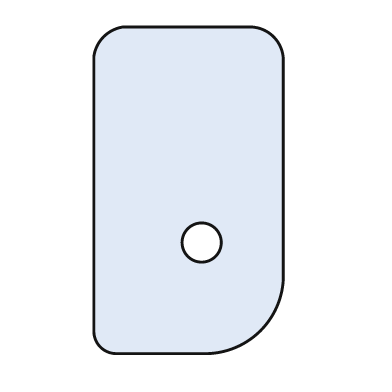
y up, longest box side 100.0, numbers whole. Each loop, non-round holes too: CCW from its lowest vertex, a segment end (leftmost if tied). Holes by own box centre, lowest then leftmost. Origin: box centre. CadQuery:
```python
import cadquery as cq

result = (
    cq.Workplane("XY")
    .moveTo(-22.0, -50.0)
    .lineTo(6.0, -50.0)
    .threePointArc((22.0, -43.0), (29.0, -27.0))
    .lineTo(29.0, 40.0)
    .threePointArc((26.0, 47.0), (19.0, 50.0))
    .lineTo(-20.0, 50.0)
    .threePointArc((-26.0, 47.0), (-29.0, 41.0))
    .lineTo(-29.0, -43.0)
    .threePointArc((-27.0, -48.0), (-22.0, -50.0))
    .close()
    .moveTo(4.0, -16.0)
    .circle(6.0)
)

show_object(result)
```